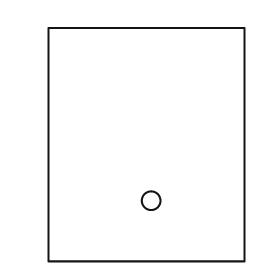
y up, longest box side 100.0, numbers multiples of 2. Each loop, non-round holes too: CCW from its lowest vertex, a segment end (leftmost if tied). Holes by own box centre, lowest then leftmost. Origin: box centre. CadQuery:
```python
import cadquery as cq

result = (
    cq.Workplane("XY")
    .moveTo(-42.0, -50.0)
    .lineTo(42.0, -50.0)
    .lineTo(42.0, 50.0)
    .lineTo(-42.0, 50.0)
    .close()
    .moveTo(2.0, -24.0)
    .circle(4.0)
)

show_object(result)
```